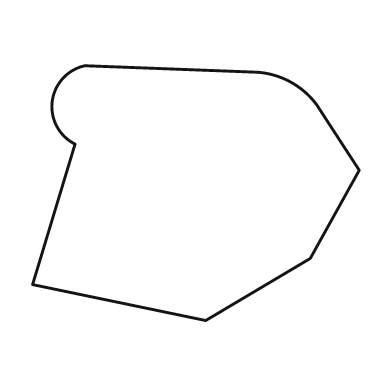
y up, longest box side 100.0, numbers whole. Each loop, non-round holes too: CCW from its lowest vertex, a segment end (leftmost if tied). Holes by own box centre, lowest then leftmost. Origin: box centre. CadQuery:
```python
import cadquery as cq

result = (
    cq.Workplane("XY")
    .moveTo(3.0, -39.0)
    .lineTo(35.0, -20.0)
    .lineTo(50.0, 7.0)
    .lineTo(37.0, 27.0)
    .threePointArc((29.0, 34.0), (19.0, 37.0))
    .lineTo(-34.0, 39.0)
    .threePointArc((-44.0, 28.0), (-37.0, 15.0))
    .lineTo(-50.0, -28.0)
    .close()
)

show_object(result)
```